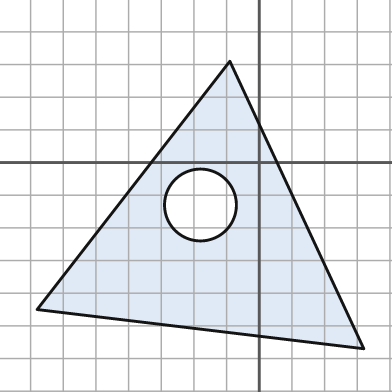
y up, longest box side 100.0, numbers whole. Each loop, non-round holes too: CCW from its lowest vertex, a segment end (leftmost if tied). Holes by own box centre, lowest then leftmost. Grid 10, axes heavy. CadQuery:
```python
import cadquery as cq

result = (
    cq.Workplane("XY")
    .moveTo(32.0, -57.0)
    .lineTo(-9.0, 31.0)
    .lineTo(-68.0, -45.0)
    .close()
    .moveTo(-18.0, -13.0)
    .circle(11.0)
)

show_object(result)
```